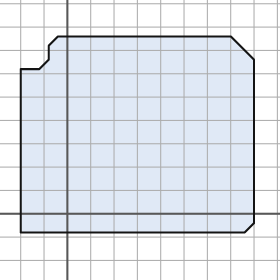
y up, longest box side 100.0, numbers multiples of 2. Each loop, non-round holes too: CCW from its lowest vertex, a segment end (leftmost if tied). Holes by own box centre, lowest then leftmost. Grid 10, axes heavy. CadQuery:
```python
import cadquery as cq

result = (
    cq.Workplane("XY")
    .moveTo(-20.0, -8.0)
    .lineTo(76.0, -8.0)
    .lineTo(80.0, -4.0)
    .lineTo(80.0, 66.0)
    .lineTo(70.0, 76.0)
    .lineTo(-4.0, 76.0)
    .lineTo(-8.0, 72.0)
    .lineTo(-8.0, 66.0)
    .lineTo(-12.0, 62.0)
    .lineTo(-20.0, 62.0)
    .close()
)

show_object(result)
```